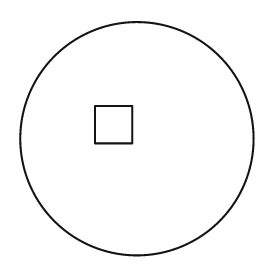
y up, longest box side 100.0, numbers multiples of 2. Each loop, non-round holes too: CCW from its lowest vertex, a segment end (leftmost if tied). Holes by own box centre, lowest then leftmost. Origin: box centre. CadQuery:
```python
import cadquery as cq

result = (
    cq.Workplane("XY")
    .moveTo(0.0, 0.0)
    .circle(50.0)
    .moveTo(-18.0, -2.0)
    .lineTo(-2.0, -2.0)
    .lineTo(-2.0, 14.0)
    .lineTo(-18.0, 14.0)
    .close()
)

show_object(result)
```